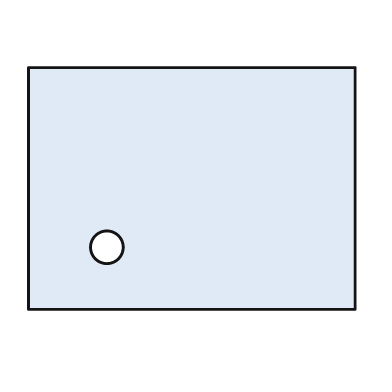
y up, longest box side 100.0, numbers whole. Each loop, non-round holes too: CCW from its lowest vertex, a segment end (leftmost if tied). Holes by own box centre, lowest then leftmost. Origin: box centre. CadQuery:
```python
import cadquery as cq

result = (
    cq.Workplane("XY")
    .moveTo(-50.0, -37.0)
    .lineTo(50.0, -37.0)
    .lineTo(50.0, 37.0)
    .lineTo(-50.0, 37.0)
    .close()
    .moveTo(-26.0, -18.0)
    .circle(5.0)
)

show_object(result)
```